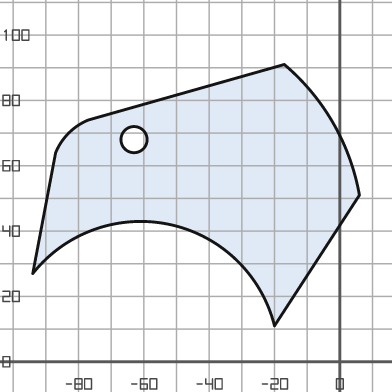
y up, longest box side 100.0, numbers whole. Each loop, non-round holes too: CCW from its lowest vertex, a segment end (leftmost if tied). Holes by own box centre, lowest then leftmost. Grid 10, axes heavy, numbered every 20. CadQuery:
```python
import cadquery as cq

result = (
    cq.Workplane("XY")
    .moveTo(-20.0, 11.0)
    .lineTo(6.0, 51.0)
    .threePointArc((-2.0, 73.0), (-17.0, 91.0))
    .lineTo(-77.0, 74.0)
    .threePointArc((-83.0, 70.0), (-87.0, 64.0))
    .lineTo(-94.0, 27.0)
    .threePointArc((-52.0, 42.0), (-20.0, 11.0))
    .close()
    .moveTo(-63.0, 68.0)
    .circle(4.0)
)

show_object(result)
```